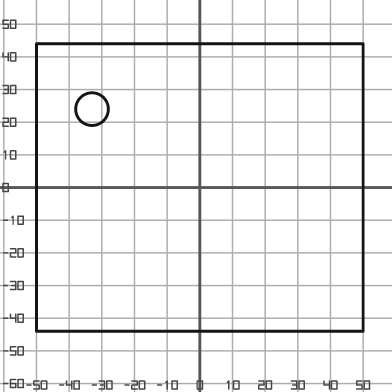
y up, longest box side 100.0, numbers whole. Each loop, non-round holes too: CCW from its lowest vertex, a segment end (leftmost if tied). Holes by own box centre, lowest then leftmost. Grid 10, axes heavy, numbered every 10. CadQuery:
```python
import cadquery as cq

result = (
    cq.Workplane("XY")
    .moveTo(-50.0, -44.0)
    .lineTo(50.0, -44.0)
    .lineTo(50.0, 44.0)
    .lineTo(-50.0, 44.0)
    .close()
    .moveTo(-33.0, 24.0)
    .circle(5.0)
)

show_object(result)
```